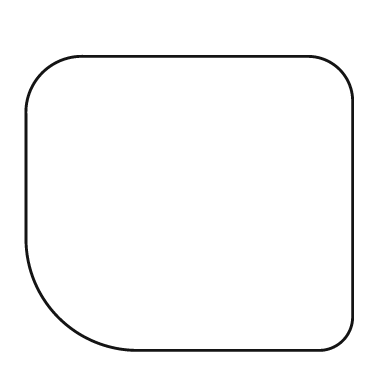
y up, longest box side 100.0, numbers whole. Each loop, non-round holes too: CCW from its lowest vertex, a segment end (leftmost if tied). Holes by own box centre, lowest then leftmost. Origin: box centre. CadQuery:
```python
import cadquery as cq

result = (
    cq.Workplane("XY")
    .moveTo(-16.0, -45.0)
    .lineTo(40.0, -45.0)
    .threePointArc((47.0, -42.0), (50.0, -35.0))
    .lineTo(50.0, 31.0)
    .threePointArc((46.0, 41.0), (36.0, 45.0))
    .lineTo(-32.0, 45.0)
    .threePointArc((-45.0, 40.0), (-50.0, 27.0))
    .lineTo(-50.0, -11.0)
    .threePointArc((-40.0, -35.0), (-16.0, -45.0))
    .close()
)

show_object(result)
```